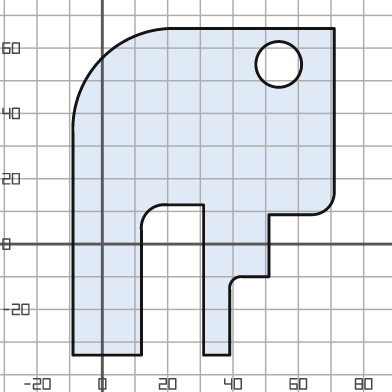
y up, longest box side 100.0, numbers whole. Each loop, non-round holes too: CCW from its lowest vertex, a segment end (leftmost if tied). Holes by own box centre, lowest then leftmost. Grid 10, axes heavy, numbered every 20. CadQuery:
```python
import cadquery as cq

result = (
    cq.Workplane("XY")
    .moveTo(-9.0, -34.0)
    .lineTo(12.0, -34.0)
    .lineTo(12.0, 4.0)
    .threePointArc((14.0, 10.0), (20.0, 12.0))
    .lineTo(31.0, 12.0)
    .lineTo(31.0, -34.0)
    .lineTo(39.0, -34.0)
    .lineTo(39.0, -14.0)
    .threePointArc((40.0, -11.0), (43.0, -10.0))
    .lineTo(51.0, -10.0)
    .lineTo(51.0, 9.0)
    .lineTo(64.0, 9.0)
    .threePointArc((69.0, 11.0), (71.0, 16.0))
    .lineTo(71.0, 66.0)
    .lineTo(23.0, 66.0)
    .threePointArc((0.0, 57.0), (-9.0, 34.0))
    .close()
    .moveTo(54.0, 55.0)
    .circle(7.0)
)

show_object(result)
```